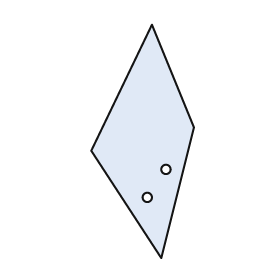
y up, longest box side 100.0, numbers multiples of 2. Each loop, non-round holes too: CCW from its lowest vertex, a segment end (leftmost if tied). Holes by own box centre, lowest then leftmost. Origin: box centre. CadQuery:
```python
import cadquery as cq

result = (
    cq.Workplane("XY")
    .moveTo(8.0, -50.0)
    .lineTo(22.0, 6.0)
    .lineTo(4.0, 50.0)
    .lineTo(-22.0, -4.0)
    .close()
    .moveTo(2.0, -24.0)
    .circle(2.0)
    .moveTo(10.0, -12.0)
    .circle(2.0)
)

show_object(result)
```